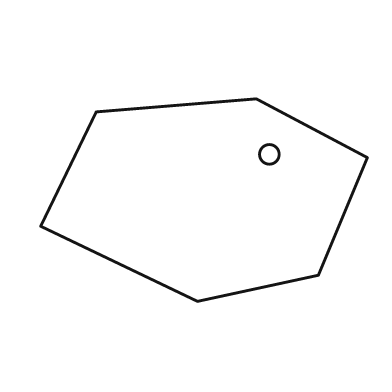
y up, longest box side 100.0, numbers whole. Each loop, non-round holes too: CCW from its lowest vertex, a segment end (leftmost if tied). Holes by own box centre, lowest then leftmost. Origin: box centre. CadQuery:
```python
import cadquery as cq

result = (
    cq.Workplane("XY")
    .moveTo(-2.0, -31.0)
    .lineTo(35.0, -23.0)
    .lineTo(50.0, 13.0)
    .lineTo(16.0, 31.0)
    .lineTo(-33.0, 27.0)
    .lineTo(-50.0, -8.0)
    .close()
    .moveTo(20.0, 14.0)
    .circle(3.0)
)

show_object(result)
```